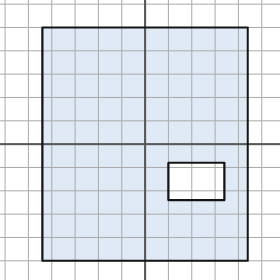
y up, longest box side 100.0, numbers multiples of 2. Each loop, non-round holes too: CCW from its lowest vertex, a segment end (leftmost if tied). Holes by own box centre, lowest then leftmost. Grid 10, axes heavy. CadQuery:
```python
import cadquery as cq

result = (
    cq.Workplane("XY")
    .moveTo(-44.0, -50.0)
    .lineTo(44.0, -50.0)
    .lineTo(44.0, 50.0)
    .lineTo(-44.0, 50.0)
    .close()
    .moveTo(10.0, -24.0)
    .lineTo(34.0, -24.0)
    .lineTo(34.0, -8.0)
    .lineTo(10.0, -8.0)
    .close()
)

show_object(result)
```